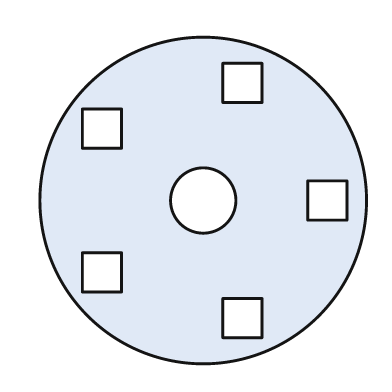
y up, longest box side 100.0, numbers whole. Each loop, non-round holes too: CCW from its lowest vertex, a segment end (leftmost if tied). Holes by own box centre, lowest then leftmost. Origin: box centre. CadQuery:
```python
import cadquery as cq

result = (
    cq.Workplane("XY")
    .moveTo(0.0, 0.0)
    .circle(50.0)
    .moveTo(6.0, -42.0)
    .lineTo(18.0, -42.0)
    .lineTo(18.0, -30.0)
    .lineTo(6.0, -30.0)
    .close()
    .moveTo(-37.0, -28.0)
    .lineTo(-25.0, -28.0)
    .lineTo(-25.0, -16.0)
    .lineTo(-37.0, -16.0)
    .close()
    .moveTo(0.0, 0.0)
    .circle(10.0)
    .moveTo(32.0, -6.0)
    .lineTo(44.0, -6.0)
    .lineTo(44.0, 6.0)
    .lineTo(32.0, 6.0)
    .close()
    .moveTo(-37.0, 16.0)
    .lineTo(-25.0, 16.0)
    .lineTo(-25.0, 28.0)
    .lineTo(-37.0, 28.0)
    .close()
    .moveTo(6.0, 30.0)
    .lineTo(18.0, 30.0)
    .lineTo(18.0, 42.0)
    .lineTo(6.0, 42.0)
    .close()
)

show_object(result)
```